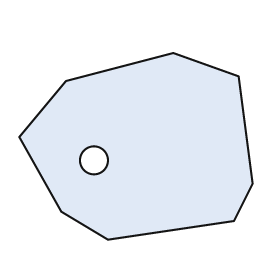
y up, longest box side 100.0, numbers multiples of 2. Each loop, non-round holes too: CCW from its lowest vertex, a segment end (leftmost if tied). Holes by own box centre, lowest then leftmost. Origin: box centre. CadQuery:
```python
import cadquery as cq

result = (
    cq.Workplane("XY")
    .moveTo(-12.0, -40.0)
    .lineTo(42.0, -32.0)
    .lineTo(50.0, -16.0)
    .lineTo(44.0, 30.0)
    .lineTo(16.0, 40.0)
    .lineTo(-30.0, 28.0)
    .lineTo(-50.0, 4.0)
    .lineTo(-32.0, -28.0)
    .close()
    .moveTo(-18.0, -6.0)
    .circle(6.0)
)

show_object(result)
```